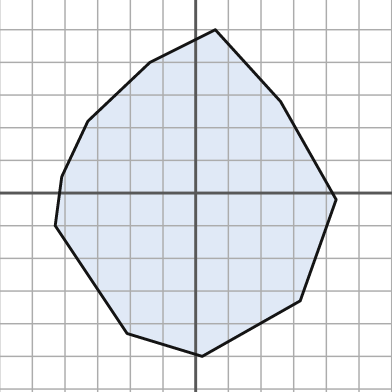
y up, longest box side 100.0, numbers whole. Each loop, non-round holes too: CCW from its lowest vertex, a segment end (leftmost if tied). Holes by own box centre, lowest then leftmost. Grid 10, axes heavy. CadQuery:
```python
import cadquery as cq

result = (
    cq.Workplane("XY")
    .moveTo(2.0, -50.0)
    .lineTo(32.0, -33.0)
    .lineTo(43.0, -2.0)
    .lineTo(26.0, 28.0)
    .lineTo(6.0, 50.0)
    .lineTo(-14.0, 40.0)
    .lineTo(-33.0, 22.0)
    .lineTo(-41.0, 5.0)
    .lineTo(-43.0, -10.0)
    .lineTo(-21.0, -43.0)
    .close()
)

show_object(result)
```